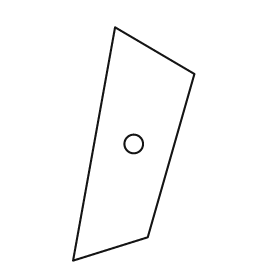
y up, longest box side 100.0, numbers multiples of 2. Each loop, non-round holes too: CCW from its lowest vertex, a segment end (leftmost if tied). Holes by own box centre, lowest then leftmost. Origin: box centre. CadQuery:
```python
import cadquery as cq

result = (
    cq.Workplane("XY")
    .moveTo(-26.0, -50.0)
    .lineTo(6.0, -40.0)
    .lineTo(26.0, 30.0)
    .lineTo(-8.0, 50.0)
    .close()
    .moveTo(0.0, 0.0)
    .circle(4.0)
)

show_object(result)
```